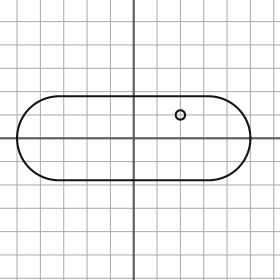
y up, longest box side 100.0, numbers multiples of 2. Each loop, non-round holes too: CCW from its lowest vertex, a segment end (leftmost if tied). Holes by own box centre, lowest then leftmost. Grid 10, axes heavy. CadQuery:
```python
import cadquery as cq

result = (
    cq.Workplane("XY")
    .moveTo(-32.0, -18.0)
    .lineTo(32.0, -18.0)
    .threePointArc((50.0, 0.0), (32.0, 18.0))
    .lineTo(-32.0, 18.0)
    .threePointArc((-50.0, 0.0), (-32.0, -18.0))
    .close()
    .moveTo(20.0, 10.0)
    .circle(2.0)
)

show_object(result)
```